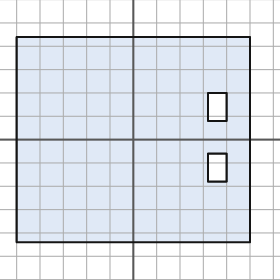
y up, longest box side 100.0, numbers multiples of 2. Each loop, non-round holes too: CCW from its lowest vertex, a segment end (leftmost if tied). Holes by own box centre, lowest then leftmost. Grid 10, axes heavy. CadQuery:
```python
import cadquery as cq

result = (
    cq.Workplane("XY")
    .moveTo(-50.0, -44.0)
    .lineTo(50.0, -44.0)
    .lineTo(50.0, 44.0)
    .lineTo(-50.0, 44.0)
    .close()
    .moveTo(32.0, -18.0)
    .lineTo(40.0, -18.0)
    .lineTo(40.0, -6.0)
    .lineTo(32.0, -6.0)
    .close()
    .moveTo(32.0, 8.0)
    .lineTo(40.0, 8.0)
    .lineTo(40.0, 20.0)
    .lineTo(32.0, 20.0)
    .close()
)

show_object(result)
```